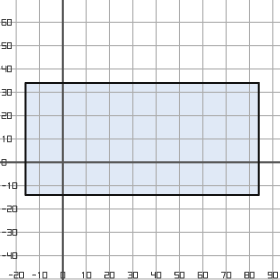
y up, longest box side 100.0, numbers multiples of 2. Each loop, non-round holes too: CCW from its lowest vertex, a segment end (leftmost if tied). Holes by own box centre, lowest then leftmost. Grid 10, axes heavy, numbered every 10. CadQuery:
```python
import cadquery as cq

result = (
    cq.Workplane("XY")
    .moveTo(-16.0, -14.0)
    .lineTo(84.0, -14.0)
    .lineTo(84.0, 34.0)
    .lineTo(-16.0, 34.0)
    .close()
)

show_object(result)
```